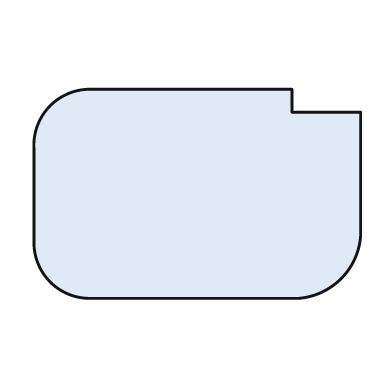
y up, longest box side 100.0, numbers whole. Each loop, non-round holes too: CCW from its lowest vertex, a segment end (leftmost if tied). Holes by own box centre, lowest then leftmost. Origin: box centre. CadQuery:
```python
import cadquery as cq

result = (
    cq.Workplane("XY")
    .moveTo(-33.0, -32.0)
    .lineTo(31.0, -32.0)
    .threePointArc((44.0, -26.0), (50.0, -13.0))
    .lineTo(50.0, 25.0)
    .lineTo(29.0, 25.0)
    .lineTo(29.0, 32.0)
    .lineTo(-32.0, 32.0)
    .threePointArc((-45.0, 27.0), (-50.0, 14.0))
    .lineTo(-50.0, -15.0)
    .threePointArc((-45.0, -27.0), (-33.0, -32.0))
    .close()
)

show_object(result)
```